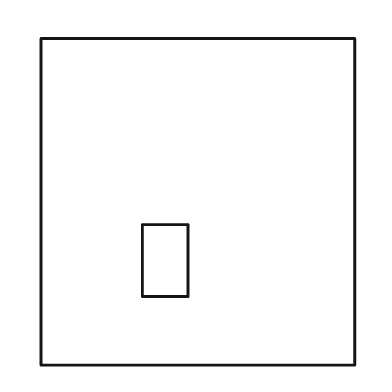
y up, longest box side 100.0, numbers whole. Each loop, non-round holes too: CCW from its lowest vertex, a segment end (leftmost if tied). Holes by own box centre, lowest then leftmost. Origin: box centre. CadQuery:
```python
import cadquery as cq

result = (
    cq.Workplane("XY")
    .moveTo(-48.0, -50.0)
    .lineTo(48.0, -50.0)
    .lineTo(48.0, 50.0)
    .lineTo(-48.0, 50.0)
    .close()
    .moveTo(-17.0, -29.0)
    .lineTo(-3.0, -29.0)
    .lineTo(-3.0, -7.0)
    .lineTo(-17.0, -7.0)
    .close()
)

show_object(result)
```